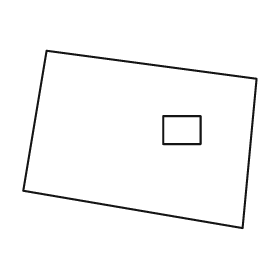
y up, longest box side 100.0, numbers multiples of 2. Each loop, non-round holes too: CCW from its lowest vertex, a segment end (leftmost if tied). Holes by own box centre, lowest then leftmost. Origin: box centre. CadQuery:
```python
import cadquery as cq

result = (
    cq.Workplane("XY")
    .moveTo(44.0, -38.0)
    .lineTo(50.0, 26.0)
    .lineTo(-40.0, 38.0)
    .lineTo(-50.0, -22.0)
    .close()
    .moveTo(10.0, -2.0)
    .lineTo(26.0, -2.0)
    .lineTo(26.0, 10.0)
    .lineTo(10.0, 10.0)
    .close()
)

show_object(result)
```